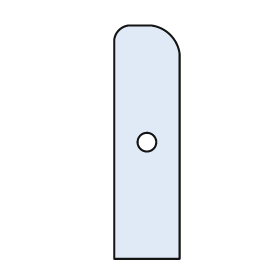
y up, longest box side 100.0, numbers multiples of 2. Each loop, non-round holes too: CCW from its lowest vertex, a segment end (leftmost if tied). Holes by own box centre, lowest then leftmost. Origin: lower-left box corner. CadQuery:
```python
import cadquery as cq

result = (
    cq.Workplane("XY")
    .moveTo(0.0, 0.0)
    .lineTo(28.0, 0.0)
    .lineTo(28.0, 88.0)
    .threePointArc((24.0, 96.0), (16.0, 100.0))
    .lineTo(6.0, 100.0)
    .threePointArc((2.0, 98.0), (0.0, 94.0))
    .close()
    .moveTo(14.0, 50.0)
    .circle(4.0)
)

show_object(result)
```